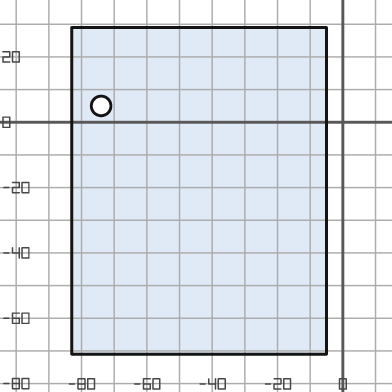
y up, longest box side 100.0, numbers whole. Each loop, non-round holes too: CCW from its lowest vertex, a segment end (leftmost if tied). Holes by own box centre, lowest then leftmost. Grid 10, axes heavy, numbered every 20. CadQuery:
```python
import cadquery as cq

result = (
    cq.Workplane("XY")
    .moveTo(-83.0, -71.0)
    .lineTo(-5.0, -71.0)
    .lineTo(-5.0, 29.0)
    .lineTo(-83.0, 29.0)
    .close()
    .moveTo(-74.0, 5.0)
    .circle(3.0)
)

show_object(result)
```